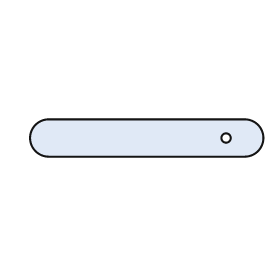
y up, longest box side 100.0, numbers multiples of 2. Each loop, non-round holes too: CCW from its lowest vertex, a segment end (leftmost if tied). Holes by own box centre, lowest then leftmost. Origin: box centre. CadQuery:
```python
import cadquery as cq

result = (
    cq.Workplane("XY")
    .moveTo(-42.0, -8.0)
    .lineTo(42.0, -8.0)
    .threePointArc((50.0, 0.0), (42.0, 8.0))
    .lineTo(-42.0, 8.0)
    .threePointArc((-50.0, 0.0), (-42.0, -8.0))
    .close()
    .moveTo(34.0, 0.0)
    .circle(2.0)
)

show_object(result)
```